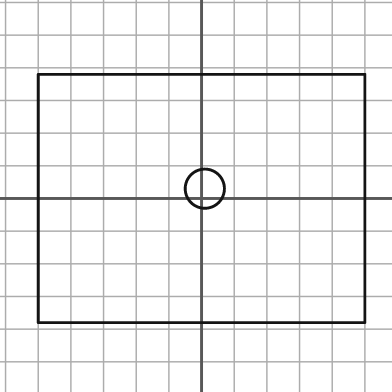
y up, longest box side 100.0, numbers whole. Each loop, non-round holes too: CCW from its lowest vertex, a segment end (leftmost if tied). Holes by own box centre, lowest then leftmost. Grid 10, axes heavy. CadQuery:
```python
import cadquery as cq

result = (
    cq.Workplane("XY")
    .moveTo(-50.0, -38.0)
    .lineTo(50.0, -38.0)
    .lineTo(50.0, 38.0)
    .lineTo(-50.0, 38.0)
    .close()
    .moveTo(1.0, 3.0)
    .circle(6.0)
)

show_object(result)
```